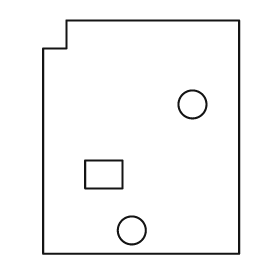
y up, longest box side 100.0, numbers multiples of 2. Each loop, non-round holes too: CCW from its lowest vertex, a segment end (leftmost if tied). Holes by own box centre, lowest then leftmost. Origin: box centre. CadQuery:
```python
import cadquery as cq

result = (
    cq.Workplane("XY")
    .moveTo(-42.0, -50.0)
    .lineTo(42.0, -50.0)
    .lineTo(42.0, 50.0)
    .lineTo(-32.0, 50.0)
    .lineTo(-32.0, 38.0)
    .lineTo(-42.0, 38.0)
    .close()
    .moveTo(-4.0, -40.0)
    .circle(6.0)
    .moveTo(-24.0, -22.0)
    .lineTo(-8.0, -22.0)
    .lineTo(-8.0, -10.0)
    .lineTo(-24.0, -10.0)
    .close()
    .moveTo(22.0, 14.0)
    .circle(6.0)
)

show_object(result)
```